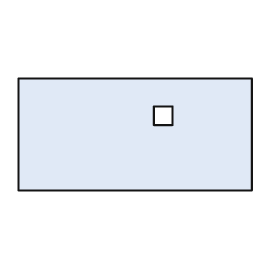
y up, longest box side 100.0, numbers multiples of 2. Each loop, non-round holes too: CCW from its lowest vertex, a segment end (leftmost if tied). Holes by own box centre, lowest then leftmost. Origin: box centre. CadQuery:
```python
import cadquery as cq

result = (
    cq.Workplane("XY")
    .moveTo(-50.0, -24.0)
    .lineTo(50.0, -24.0)
    .lineTo(50.0, 24.0)
    .lineTo(-50.0, 24.0)
    .close()
    .moveTo(8.0, 4.0)
    .lineTo(16.0, 4.0)
    .lineTo(16.0, 12.0)
    .lineTo(8.0, 12.0)
    .close()
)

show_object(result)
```